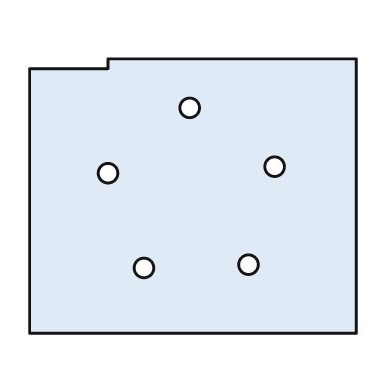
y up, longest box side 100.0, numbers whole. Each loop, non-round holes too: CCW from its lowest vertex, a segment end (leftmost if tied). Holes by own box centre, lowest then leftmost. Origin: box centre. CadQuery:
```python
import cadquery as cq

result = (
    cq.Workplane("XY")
    .moveTo(-50.0, -42.0)
    .lineTo(50.0, -42.0)
    .lineTo(50.0, 42.0)
    .lineTo(-26.0, 42.0)
    .lineTo(-26.0, 39.0)
    .lineTo(-50.0, 39.0)
    .close()
    .moveTo(-15.0, -22.0)
    .circle(3.0)
    .moveTo(17.0, -21.0)
    .circle(3.0)
    .moveTo(-26.0, 7.0)
    .circle(3.0)
    .moveTo(25.0, 9.0)
    .circle(3.0)
    .moveTo(-1.0, 27.0)
    .circle(3.0)
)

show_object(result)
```